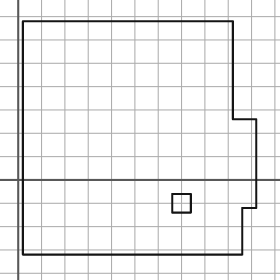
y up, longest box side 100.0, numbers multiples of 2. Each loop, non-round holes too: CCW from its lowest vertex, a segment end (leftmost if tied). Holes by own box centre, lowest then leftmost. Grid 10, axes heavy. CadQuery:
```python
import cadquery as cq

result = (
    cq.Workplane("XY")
    .moveTo(2.0, -32.0)
    .lineTo(96.0, -32.0)
    .lineTo(96.0, -12.0)
    .lineTo(102.0, -12.0)
    .lineTo(102.0, 26.0)
    .lineTo(92.0, 26.0)
    .lineTo(92.0, 68.0)
    .lineTo(2.0, 68.0)
    .close()
    .moveTo(66.0, -14.0)
    .lineTo(74.0, -14.0)
    .lineTo(74.0, -6.0)
    .lineTo(66.0, -6.0)
    .close()
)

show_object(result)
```